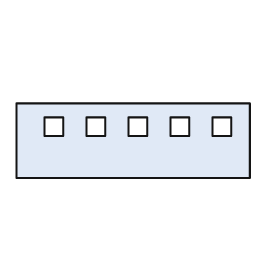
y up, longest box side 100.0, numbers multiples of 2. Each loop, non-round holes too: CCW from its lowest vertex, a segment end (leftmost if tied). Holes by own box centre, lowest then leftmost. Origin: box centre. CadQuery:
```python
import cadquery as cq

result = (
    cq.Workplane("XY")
    .moveTo(-50.0, -16.0)
    .lineTo(50.0, -16.0)
    .lineTo(50.0, 16.0)
    .lineTo(-50.0, 16.0)
    .close()
    .moveTo(-38.0, 2.0)
    .lineTo(-30.0, 2.0)
    .lineTo(-30.0, 10.0)
    .lineTo(-38.0, 10.0)
    .close()
    .moveTo(-20.0, 2.0)
    .lineTo(-12.0, 2.0)
    .lineTo(-12.0, 10.0)
    .lineTo(-20.0, 10.0)
    .close()
    .moveTo(-2.0, 2.0)
    .lineTo(6.0, 2.0)
    .lineTo(6.0, 10.0)
    .lineTo(-2.0, 10.0)
    .close()
    .moveTo(16.0, 2.0)
    .lineTo(24.0, 2.0)
    .lineTo(24.0, 10.0)
    .lineTo(16.0, 10.0)
    .close()
    .moveTo(34.0, 2.0)
    .lineTo(42.0, 2.0)
    .lineTo(42.0, 10.0)
    .lineTo(34.0, 10.0)
    .close()
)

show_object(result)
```